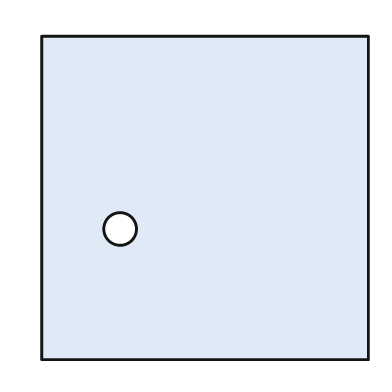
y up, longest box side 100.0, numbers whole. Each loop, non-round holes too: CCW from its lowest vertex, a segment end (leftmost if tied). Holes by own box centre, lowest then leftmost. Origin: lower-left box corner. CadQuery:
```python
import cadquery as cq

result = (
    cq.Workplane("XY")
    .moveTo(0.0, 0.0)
    .lineTo(100.0, 0.0)
    .lineTo(100.0, 99.0)
    .lineTo(0.0, 99.0)
    .close()
    .moveTo(24.0, 40.0)
    .circle(5.0)
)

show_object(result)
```